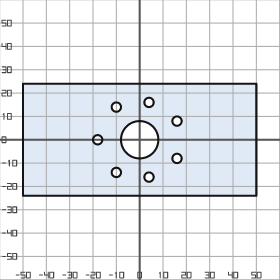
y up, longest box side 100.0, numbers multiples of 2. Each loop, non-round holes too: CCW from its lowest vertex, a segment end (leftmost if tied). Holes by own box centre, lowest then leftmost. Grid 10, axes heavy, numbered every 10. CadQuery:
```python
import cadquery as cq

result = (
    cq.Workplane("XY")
    .moveTo(-50.0, -24.0)
    .lineTo(50.0, -24.0)
    .lineTo(50.0, 24.0)
    .lineTo(-50.0, 24.0)
    .close()
    .moveTo(4.0, -16.0)
    .circle(2.0)
    .moveTo(-10.0, -14.0)
    .circle(2.0)
    .moveTo(16.0, -8.0)
    .circle(2.0)
    .moveTo(-18.0, 0.0)
    .circle(2.0)
    .moveTo(0.0, 0.0)
    .circle(8.0)
    .moveTo(16.0, 8.0)
    .circle(2.0)
    .moveTo(-10.0, 14.0)
    .circle(2.0)
    .moveTo(4.0, 16.0)
    .circle(2.0)
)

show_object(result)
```